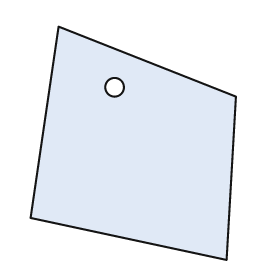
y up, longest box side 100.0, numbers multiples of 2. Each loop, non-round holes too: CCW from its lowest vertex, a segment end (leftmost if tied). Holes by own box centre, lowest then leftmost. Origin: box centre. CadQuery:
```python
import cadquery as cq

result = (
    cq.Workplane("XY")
    .moveTo(40.0, -50.0)
    .lineTo(44.0, 20.0)
    .lineTo(-32.0, 50.0)
    .lineTo(-44.0, -32.0)
    .close()
    .moveTo(-8.0, 24.0)
    .circle(4.0)
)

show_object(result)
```